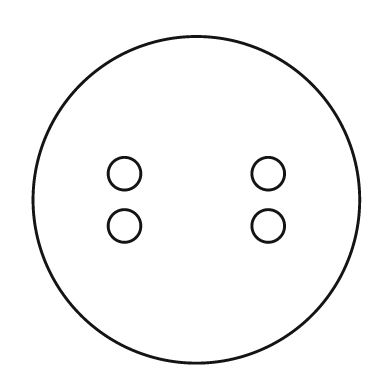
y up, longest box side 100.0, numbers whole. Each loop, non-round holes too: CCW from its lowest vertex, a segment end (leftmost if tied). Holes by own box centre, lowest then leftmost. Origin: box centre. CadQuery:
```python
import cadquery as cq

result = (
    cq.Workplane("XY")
    .moveTo(0.0, 0.0)
    .circle(50.0)
    .moveTo(-22.0, -8.0)
    .circle(5.0)
    .moveTo(22.0, -8.0)
    .circle(5.0)
    .moveTo(-22.0, 8.0)
    .circle(5.0)
    .moveTo(22.0, 8.0)
    .circle(5.0)
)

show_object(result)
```